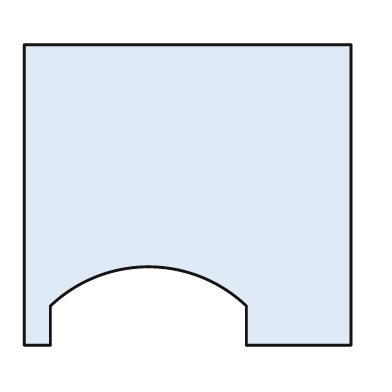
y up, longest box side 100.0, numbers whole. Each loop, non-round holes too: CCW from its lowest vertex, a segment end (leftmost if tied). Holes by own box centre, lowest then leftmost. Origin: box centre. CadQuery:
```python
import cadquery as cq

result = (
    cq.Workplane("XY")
    .moveTo(-50.0, -46.0)
    .lineTo(-42.0, -46.0)
    .lineTo(-42.0, -34.0)
    .threePointArc((-12.0, -22.0), (18.0, -34.0))
    .lineTo(18.0, -46.0)
    .lineTo(50.0, -46.0)
    .lineTo(50.0, 46.0)
    .lineTo(-50.0, 46.0)
    .close()
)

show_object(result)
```